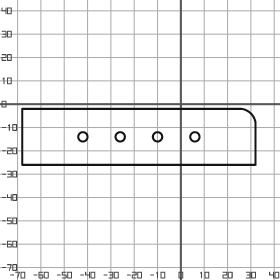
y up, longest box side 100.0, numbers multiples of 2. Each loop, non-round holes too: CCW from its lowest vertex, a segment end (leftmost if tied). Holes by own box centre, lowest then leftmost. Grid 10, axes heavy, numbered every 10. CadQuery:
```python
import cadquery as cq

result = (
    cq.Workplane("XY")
    .moveTo(-68.0, -26.0)
    .lineTo(32.0, -26.0)
    .lineTo(32.0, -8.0)
    .threePointArc((30.0, -4.0), (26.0, -2.0))
    .lineTo(-68.0, -2.0)
    .close()
    .moveTo(-42.0, -14.0)
    .circle(2.0)
    .moveTo(-26.0, -14.0)
    .circle(2.0)
    .moveTo(-10.0, -14.0)
    .circle(2.0)
    .moveTo(6.0, -14.0)
    .circle(2.0)
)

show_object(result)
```